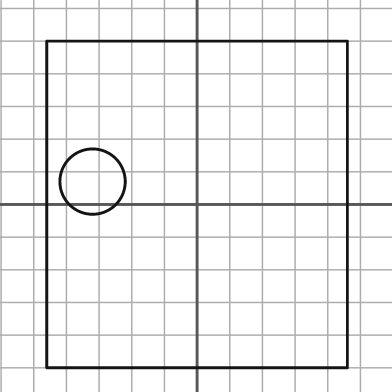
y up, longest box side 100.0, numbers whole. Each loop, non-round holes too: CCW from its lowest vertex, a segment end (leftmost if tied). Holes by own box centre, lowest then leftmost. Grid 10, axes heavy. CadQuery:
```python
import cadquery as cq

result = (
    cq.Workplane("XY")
    .moveTo(-46.0, -50.0)
    .lineTo(46.0, -50.0)
    .lineTo(46.0, 50.0)
    .lineTo(-46.0, 50.0)
    .close()
    .moveTo(-32.0, 7.0)
    .circle(10.0)
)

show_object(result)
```